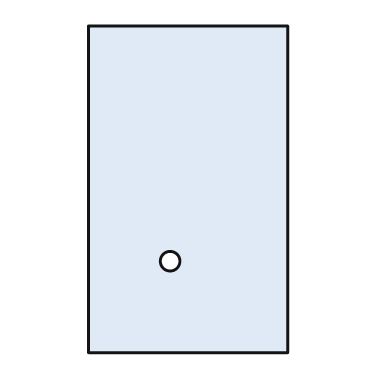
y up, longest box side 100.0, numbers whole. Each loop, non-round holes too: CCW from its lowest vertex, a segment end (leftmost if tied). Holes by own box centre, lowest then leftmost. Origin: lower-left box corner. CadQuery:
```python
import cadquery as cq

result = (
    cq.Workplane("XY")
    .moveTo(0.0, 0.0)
    .lineTo(61.0, 0.0)
    .lineTo(61.0, 100.0)
    .lineTo(0.0, 100.0)
    .close()
    .moveTo(25.0, 28.0)
    .circle(3.0)
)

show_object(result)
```